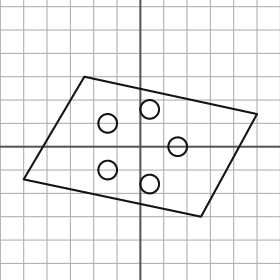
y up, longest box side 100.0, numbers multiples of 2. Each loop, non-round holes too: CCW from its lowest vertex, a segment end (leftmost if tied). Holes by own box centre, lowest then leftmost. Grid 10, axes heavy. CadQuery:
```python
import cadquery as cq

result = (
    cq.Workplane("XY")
    .moveTo(26.0, -30.0)
    .lineTo(50.0, 14.0)
    .lineTo(-24.0, 30.0)
    .lineTo(-50.0, -14.0)
    .close()
    .moveTo(4.0, -16.0)
    .circle(4.0)
    .moveTo(-14.0, -10.0)
    .circle(4.0)
    .moveTo(16.0, 0.0)
    .circle(4.0)
    .moveTo(-14.0, 10.0)
    .circle(4.0)
    .moveTo(4.0, 16.0)
    .circle(4.0)
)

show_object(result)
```